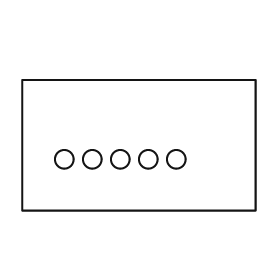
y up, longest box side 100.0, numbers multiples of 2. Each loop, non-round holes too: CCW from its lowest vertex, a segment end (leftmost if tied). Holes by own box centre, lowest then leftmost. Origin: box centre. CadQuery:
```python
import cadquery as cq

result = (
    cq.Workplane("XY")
    .moveTo(-50.0, -28.0)
    .lineTo(50.0, -28.0)
    .lineTo(50.0, 28.0)
    .lineTo(-50.0, 28.0)
    .close()
    .moveTo(-32.0, -6.0)
    .circle(4.0)
    .moveTo(-20.0, -6.0)
    .circle(4.0)
    .moveTo(-8.0, -6.0)
    .circle(4.0)
    .moveTo(4.0, -6.0)
    .circle(4.0)
    .moveTo(16.0, -6.0)
    .circle(4.0)
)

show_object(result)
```